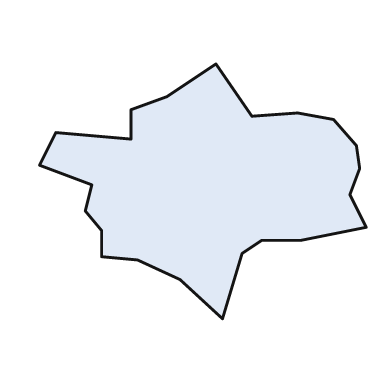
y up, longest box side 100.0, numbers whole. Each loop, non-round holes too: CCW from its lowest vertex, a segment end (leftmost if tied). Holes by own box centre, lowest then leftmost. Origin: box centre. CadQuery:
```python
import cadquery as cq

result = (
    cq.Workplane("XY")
    .moveTo(6.0, -39.0)
    .lineTo(12.0, -19.0)
    .lineTo(18.0, -15.0)
    .lineTo(30.0, -15.0)
    .lineTo(50.0, -11.0)
    .lineTo(45.0, -1.0)
    .lineTo(48.0, 7.0)
    .lineTo(47.0, 14.0)
    .lineTo(40.0, 22.0)
    .lineTo(29.0, 24.0)
    .lineTo(15.0, 23.0)
    .lineTo(4.0, 39.0)
    .lineTo(-11.0, 29.0)
    .lineTo(-22.0, 25.0)
    .lineTo(-22.0, 16.0)
    .lineTo(-45.0, 18.0)
    .lineTo(-50.0, 8.0)
    .lineTo(-34.0, 2.0)
    .lineTo(-36.0, -6.0)
    .lineTo(-31.0, -12.0)
    .lineTo(-31.0, -20.0)
    .lineTo(-20.0, -21.0)
    .lineTo(-7.0, -27.0)
    .close()
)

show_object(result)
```